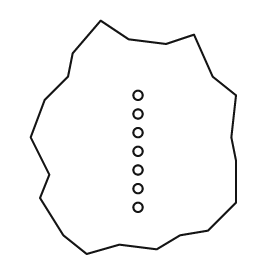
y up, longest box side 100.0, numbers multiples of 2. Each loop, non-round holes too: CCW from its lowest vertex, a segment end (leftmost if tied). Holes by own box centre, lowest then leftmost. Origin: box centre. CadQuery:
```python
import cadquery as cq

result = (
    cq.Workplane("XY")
    .moveTo(-20.0, -50.0)
    .lineTo(-6.0, -46.0)
    .lineTo(10.0, -48.0)
    .lineTo(20.0, -42.0)
    .lineTo(32.0, -40.0)
    .lineTo(44.0, -28.0)
    .lineTo(44.0, -10.0)
    .lineTo(42.0, 0.0)
    .lineTo(44.0, 18.0)
    .lineTo(34.0, 26.0)
    .lineTo(26.0, 44.0)
    .lineTo(14.0, 40.0)
    .lineTo(-2.0, 42.0)
    .lineTo(-14.0, 50.0)
    .lineTo(-26.0, 36.0)
    .lineTo(-28.0, 26.0)
    .lineTo(-38.0, 16.0)
    .lineTo(-44.0, 0.0)
    .lineTo(-36.0, -16.0)
    .lineTo(-40.0, -26.0)
    .lineTo(-30.0, -42.0)
    .close()
    .moveTo(2.0, -30.0)
    .circle(2.0)
    .moveTo(2.0, -22.0)
    .circle(2.0)
    .moveTo(2.0, -14.0)
    .circle(2.0)
    .moveTo(2.0, -6.0)
    .circle(2.0)
    .moveTo(2.0, 2.0)
    .circle(2.0)
    .moveTo(2.0, 10.0)
    .circle(2.0)
    .moveTo(2.0, 18.0)
    .circle(2.0)
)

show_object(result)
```